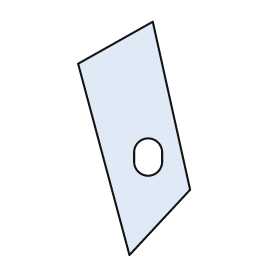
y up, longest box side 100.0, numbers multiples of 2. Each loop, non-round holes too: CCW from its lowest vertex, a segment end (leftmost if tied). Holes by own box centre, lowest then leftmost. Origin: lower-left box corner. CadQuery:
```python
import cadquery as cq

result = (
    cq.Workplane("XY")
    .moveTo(22.0, 0.0)
    .lineTo(48.0, 28.0)
    .lineTo(32.0, 100.0)
    .lineTo(0.0, 82.0)
    .close()
    .moveTo(24.0, 40.0)
    .threePointArc((30.0, 34.0), (36.0, 40.0))
    .lineTo(36.0, 44.0)
    .threePointArc((30.0, 50.0), (24.0, 44.0))
    .close()
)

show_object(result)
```